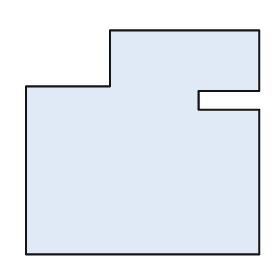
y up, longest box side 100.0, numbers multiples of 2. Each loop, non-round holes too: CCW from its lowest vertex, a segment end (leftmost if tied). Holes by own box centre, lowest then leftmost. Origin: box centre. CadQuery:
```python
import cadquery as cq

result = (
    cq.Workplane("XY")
    .moveTo(-50.0, -48.0)
    .lineTo(50.0, -48.0)
    .lineTo(50.0, 14.0)
    .lineTo(24.0, 14.0)
    .lineTo(24.0, 22.0)
    .lineTo(50.0, 22.0)
    .lineTo(50.0, 48.0)
    .lineTo(-14.0, 48.0)
    .lineTo(-14.0, 24.0)
    .lineTo(-50.0, 24.0)
    .close()
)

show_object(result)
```